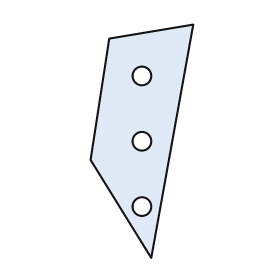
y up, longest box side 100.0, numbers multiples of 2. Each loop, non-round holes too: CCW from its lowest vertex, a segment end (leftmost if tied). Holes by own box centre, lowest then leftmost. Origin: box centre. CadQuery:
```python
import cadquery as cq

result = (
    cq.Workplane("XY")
    .moveTo(4.0, -50.0)
    .lineTo(22.0, 50.0)
    .lineTo(-14.0, 44.0)
    .lineTo(-22.0, -8.0)
    .close()
    .moveTo(0.0, -28.0)
    .circle(4.0)
    .moveTo(0.0, 0.0)
    .circle(4.0)
    .moveTo(0.0, 28.0)
    .circle(4.0)
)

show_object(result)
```